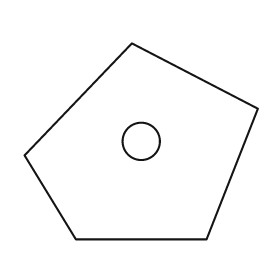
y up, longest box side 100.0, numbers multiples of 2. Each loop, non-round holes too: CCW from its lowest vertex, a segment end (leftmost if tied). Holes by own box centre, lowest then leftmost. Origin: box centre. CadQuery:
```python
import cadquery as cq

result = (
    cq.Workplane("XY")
    .moveTo(-28.0, -42.0)
    .lineTo(28.0, -42.0)
    .lineTo(50.0, 14.0)
    .lineTo(-4.0, 42.0)
    .lineTo(-50.0, -6.0)
    .close()
    .moveTo(0.0, 0.0)
    .circle(8.0)
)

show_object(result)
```